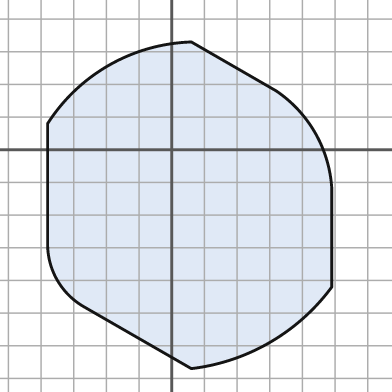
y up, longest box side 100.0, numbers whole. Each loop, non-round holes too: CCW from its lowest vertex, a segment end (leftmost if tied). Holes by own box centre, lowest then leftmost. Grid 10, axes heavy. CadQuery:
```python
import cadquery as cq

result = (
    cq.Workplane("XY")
    .moveTo(6.0, -67.0)
    .threePointArc((30.0, -59.0), (49.0, -42.0))
    .lineTo(49.0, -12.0)
    .threePointArc((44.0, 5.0), (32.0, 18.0))
    .lineTo(6.0, 33.0)
    .threePointArc((-19.0, 26.0), (-38.0, 8.0))
    .lineTo(-38.0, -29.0)
    .threePointArc((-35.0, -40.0), (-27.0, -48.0))
    .close()
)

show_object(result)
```